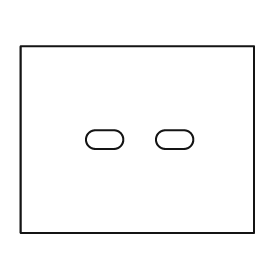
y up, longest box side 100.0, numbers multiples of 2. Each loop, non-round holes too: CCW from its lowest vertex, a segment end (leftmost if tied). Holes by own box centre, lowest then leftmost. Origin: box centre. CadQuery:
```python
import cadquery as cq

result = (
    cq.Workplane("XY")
    .moveTo(-50.0, -40.0)
    .lineTo(50.0, -40.0)
    .lineTo(50.0, 40.0)
    .lineTo(-50.0, 40.0)
    .close()
    .moveTo(-18.0, -4.0)
    .lineTo(-10.0, -4.0)
    .threePointArc((-6.0, 0.0), (-10.0, 4.0))
    .lineTo(-18.0, 4.0)
    .threePointArc((-22.0, 0.0), (-18.0, -4.0))
    .close()
    .moveTo(12.0, -4.0)
    .lineTo(20.0, -4.0)
    .threePointArc((24.0, 0.0), (20.0, 4.0))
    .lineTo(12.0, 4.0)
    .threePointArc((8.0, 0.0), (12.0, -4.0))
    .close()
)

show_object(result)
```